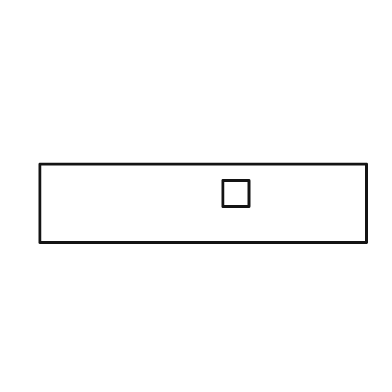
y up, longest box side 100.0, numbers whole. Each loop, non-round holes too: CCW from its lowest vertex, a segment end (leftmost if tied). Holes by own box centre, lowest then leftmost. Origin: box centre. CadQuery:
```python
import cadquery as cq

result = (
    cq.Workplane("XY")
    .moveTo(-50.0, -12.0)
    .lineTo(50.0, -12.0)
    .lineTo(50.0, 12.0)
    .lineTo(-50.0, 12.0)
    .close()
    .moveTo(6.0, -1.0)
    .lineTo(14.0, -1.0)
    .lineTo(14.0, 7.0)
    .lineTo(6.0, 7.0)
    .close()
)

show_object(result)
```